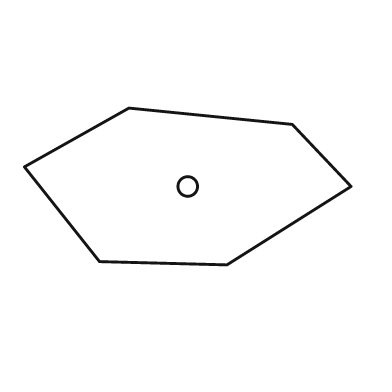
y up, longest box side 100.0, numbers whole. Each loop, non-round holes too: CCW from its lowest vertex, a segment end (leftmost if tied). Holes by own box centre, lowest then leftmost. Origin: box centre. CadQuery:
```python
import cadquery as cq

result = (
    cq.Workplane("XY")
    .moveTo(12.0, -24.0)
    .lineTo(50.0, 0.0)
    .lineTo(32.0, 19.0)
    .lineTo(-18.0, 24.0)
    .lineTo(-50.0, 6.0)
    .lineTo(-27.0, -23.0)
    .close()
    .moveTo(0.0, 0.0)
    .circle(3.0)
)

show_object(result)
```